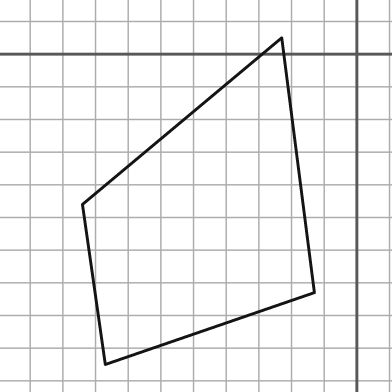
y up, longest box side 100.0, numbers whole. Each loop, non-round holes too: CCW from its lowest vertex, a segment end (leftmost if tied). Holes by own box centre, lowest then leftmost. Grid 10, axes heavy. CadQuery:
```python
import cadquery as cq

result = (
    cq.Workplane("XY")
    .moveTo(-77.0, -95.0)
    .lineTo(-13.0, -73.0)
    .lineTo(-23.0, 5.0)
    .lineTo(-84.0, -46.0)
    .close()
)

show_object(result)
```